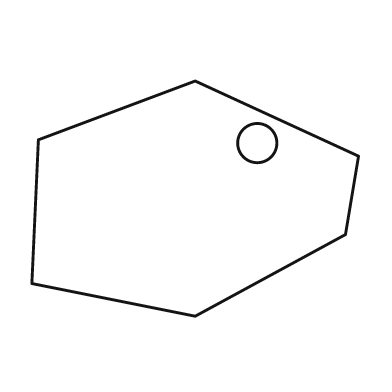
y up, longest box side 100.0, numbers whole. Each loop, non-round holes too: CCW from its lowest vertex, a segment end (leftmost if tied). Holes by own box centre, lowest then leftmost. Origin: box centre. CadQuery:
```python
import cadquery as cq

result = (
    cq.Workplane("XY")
    .moveTo(0.0, -36.0)
    .lineTo(46.0, -11.0)
    .lineTo(50.0, 13.0)
    .lineTo(0.0, 36.0)
    .lineTo(-48.0, 18.0)
    .lineTo(-50.0, -26.0)
    .close()
    .moveTo(19.0, 17.0)
    .circle(6.0)
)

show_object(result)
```